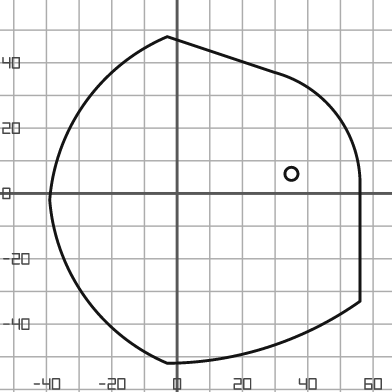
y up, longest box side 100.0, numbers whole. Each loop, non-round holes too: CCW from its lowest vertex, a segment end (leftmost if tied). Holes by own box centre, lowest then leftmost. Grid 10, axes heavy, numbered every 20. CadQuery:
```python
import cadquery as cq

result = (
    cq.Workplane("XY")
    .moveTo(-3.0, -52.0)
    .threePointArc((28.0, -47.0), (56.0, -33.0))
    .lineTo(56.0, 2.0)
    .threePointArc((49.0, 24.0), (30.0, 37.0))
    .lineTo(-3.0, 48.0)
    .threePointArc((-28.0, 28.0), (-39.0, -2.0))
    .threePointArc((-28.0, -32.0), (-3.0, -52.0))
    .close()
    .moveTo(35.0, 6.0)
    .circle(2.0)
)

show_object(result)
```